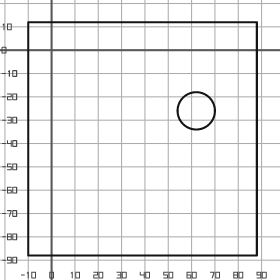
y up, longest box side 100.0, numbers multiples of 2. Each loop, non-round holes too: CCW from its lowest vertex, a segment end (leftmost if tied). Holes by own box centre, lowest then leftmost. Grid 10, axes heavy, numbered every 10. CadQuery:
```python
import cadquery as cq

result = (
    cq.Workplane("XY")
    .moveTo(-10.0, -88.0)
    .lineTo(88.0, -88.0)
    .lineTo(88.0, 12.0)
    .lineTo(-10.0, 12.0)
    .close()
    .moveTo(62.0, -26.0)
    .circle(8.0)
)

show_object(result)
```